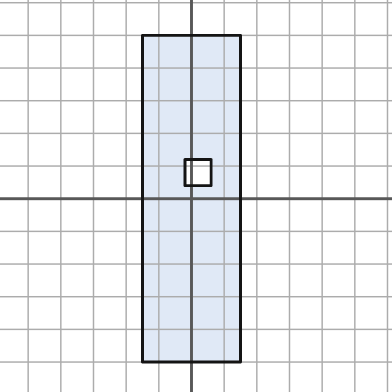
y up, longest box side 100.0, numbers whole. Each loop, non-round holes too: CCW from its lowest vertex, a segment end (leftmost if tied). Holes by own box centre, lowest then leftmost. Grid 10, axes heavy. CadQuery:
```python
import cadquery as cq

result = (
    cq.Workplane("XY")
    .moveTo(-15.0, -50.0)
    .lineTo(15.0, -50.0)
    .lineTo(15.0, 50.0)
    .lineTo(-15.0, 50.0)
    .close()
    .moveTo(-2.0, 4.0)
    .lineTo(6.0, 4.0)
    .lineTo(6.0, 12.0)
    .lineTo(-2.0, 12.0)
    .close()
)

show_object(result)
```